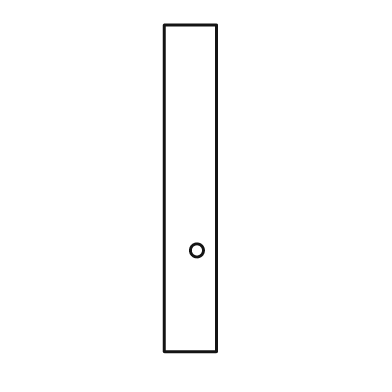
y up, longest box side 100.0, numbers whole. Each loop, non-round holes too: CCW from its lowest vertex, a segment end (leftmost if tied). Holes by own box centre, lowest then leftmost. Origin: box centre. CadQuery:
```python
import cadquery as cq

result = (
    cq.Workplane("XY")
    .moveTo(-8.0, -50.0)
    .lineTo(8.0, -50.0)
    .lineTo(8.0, 50.0)
    .lineTo(-8.0, 50.0)
    .close()
    .moveTo(2.0, -19.0)
    .circle(2.0)
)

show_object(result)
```